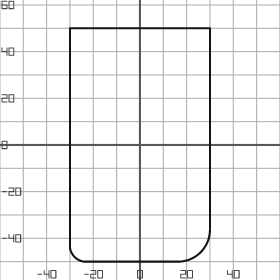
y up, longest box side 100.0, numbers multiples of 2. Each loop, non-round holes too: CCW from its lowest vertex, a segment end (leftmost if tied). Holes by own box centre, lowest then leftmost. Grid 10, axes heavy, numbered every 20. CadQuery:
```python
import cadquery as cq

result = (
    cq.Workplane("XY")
    .moveTo(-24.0, -50.0)
    .lineTo(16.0, -50.0)
    .threePointArc((26.0, -46.0), (30.0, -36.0))
    .lineTo(30.0, 50.0)
    .lineTo(-30.0, 50.0)
    .lineTo(-30.0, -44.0)
    .threePointArc((-28.0, -48.0), (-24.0, -50.0))
    .close()
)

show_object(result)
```